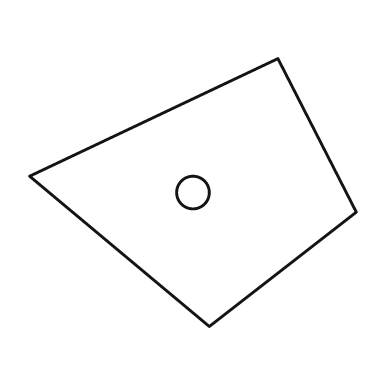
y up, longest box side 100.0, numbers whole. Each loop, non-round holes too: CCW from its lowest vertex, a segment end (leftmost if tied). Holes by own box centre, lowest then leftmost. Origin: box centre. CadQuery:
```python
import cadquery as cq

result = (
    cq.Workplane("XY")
    .moveTo(5.0, -41.0)
    .lineTo(50.0, -6.0)
    .lineTo(26.0, 41.0)
    .lineTo(-50.0, 5.0)
    .close()
    .moveTo(0.0, 0.0)
    .circle(5.0)
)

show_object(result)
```